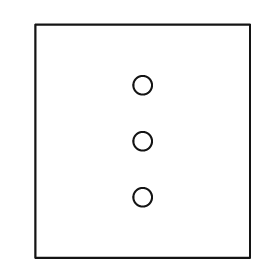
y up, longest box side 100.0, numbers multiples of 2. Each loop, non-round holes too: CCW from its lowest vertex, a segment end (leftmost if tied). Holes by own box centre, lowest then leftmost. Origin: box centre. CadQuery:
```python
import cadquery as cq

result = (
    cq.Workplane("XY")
    .moveTo(-46.0, -50.0)
    .lineTo(46.0, -50.0)
    .lineTo(46.0, 50.0)
    .lineTo(-46.0, 50.0)
    .close()
    .moveTo(0.0, -24.0)
    .circle(4.0)
    .moveTo(0.0, 0.0)
    .circle(4.0)
    .moveTo(0.0, 24.0)
    .circle(4.0)
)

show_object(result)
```